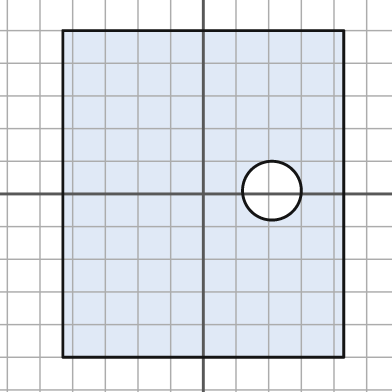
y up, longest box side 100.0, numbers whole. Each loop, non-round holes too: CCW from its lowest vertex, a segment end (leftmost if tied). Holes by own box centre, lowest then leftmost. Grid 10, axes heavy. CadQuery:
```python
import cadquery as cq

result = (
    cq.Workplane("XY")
    .moveTo(-43.0, -50.0)
    .lineTo(43.0, -50.0)
    .lineTo(43.0, 50.0)
    .lineTo(-43.0, 50.0)
    .close()
    .moveTo(21.0, 1.0)
    .circle(9.0)
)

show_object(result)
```